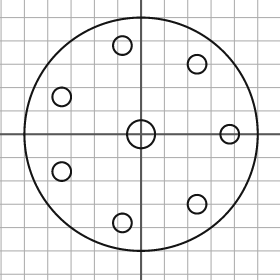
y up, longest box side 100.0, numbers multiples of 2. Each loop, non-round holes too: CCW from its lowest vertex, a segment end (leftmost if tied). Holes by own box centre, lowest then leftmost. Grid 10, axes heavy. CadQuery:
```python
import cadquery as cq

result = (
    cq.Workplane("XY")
    .moveTo(0.0, 0.0)
    .circle(50.0)
    .moveTo(-8.0, -38.0)
    .circle(4.0)
    .moveTo(24.0, -30.0)
    .circle(4.0)
    .moveTo(-34.0, -16.0)
    .circle(4.0)
    .moveTo(0.0, 0.0)
    .circle(6.0)
    .moveTo(38.0, 0.0)
    .circle(4.0)
    .moveTo(-34.0, 16.0)
    .circle(4.0)
    .moveTo(24.0, 30.0)
    .circle(4.0)
    .moveTo(-8.0, 38.0)
    .circle(4.0)
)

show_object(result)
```